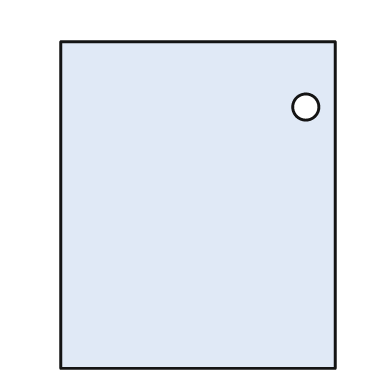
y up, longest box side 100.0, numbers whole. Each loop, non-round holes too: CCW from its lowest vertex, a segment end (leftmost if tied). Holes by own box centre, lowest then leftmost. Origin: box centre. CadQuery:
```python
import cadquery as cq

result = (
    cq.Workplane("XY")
    .moveTo(-42.0, -50.0)
    .lineTo(42.0, -50.0)
    .lineTo(42.0, 50.0)
    .lineTo(-42.0, 50.0)
    .close()
    .moveTo(33.0, 30.0)
    .circle(4.0)
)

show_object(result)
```